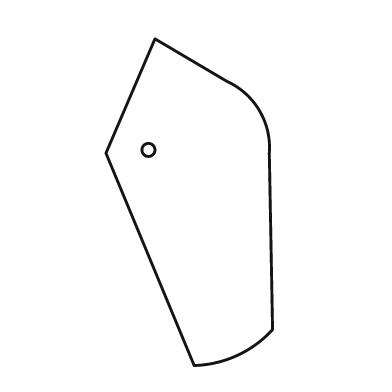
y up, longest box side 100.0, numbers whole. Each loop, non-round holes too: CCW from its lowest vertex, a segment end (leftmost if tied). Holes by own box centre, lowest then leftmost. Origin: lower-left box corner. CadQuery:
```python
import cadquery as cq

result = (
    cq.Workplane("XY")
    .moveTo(27.0, 0.0)
    .threePointArc((40.0, 3.0), (51.0, 11.0))
    .lineTo(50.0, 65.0)
    .threePointArc((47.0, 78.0), (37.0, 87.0))
    .lineTo(15.0, 100.0)
    .lineTo(0.0, 65.0)
    .close()
    .moveTo(13.0, 66.0)
    .circle(2.0)
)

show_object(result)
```